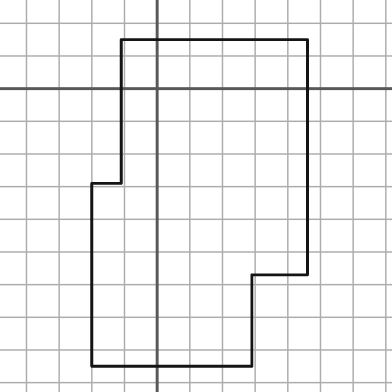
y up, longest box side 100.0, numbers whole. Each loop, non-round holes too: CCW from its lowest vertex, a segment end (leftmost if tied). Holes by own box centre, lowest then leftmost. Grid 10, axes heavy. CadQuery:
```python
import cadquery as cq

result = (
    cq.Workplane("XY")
    .moveTo(-20.0, -85.0)
    .lineTo(29.0, -85.0)
    .lineTo(29.0, -57.0)
    .lineTo(46.0, -57.0)
    .lineTo(46.0, 15.0)
    .lineTo(-11.0, 15.0)
    .lineTo(-11.0, -29.0)
    .lineTo(-20.0, -29.0)
    .close()
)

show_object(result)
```